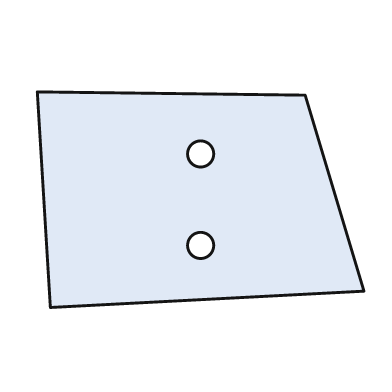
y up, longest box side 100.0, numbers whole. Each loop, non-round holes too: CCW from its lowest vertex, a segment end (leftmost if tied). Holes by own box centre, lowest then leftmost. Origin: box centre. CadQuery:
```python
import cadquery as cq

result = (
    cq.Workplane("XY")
    .moveTo(-46.0, -33.0)
    .lineTo(50.0, -28.0)
    .lineTo(32.0, 32.0)
    .lineTo(-50.0, 33.0)
    .close()
    .moveTo(0.0, -14.0)
    .circle(4.0)
    .moveTo(0.0, 14.0)
    .circle(4.0)
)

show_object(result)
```